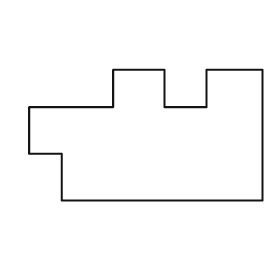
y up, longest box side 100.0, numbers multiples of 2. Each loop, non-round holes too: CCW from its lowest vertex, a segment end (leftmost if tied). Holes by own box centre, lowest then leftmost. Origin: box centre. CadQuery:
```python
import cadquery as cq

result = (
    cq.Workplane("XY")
    .moveTo(-36.0, -28.0)
    .lineTo(50.0, -28.0)
    .lineTo(50.0, 28.0)
    .lineTo(26.0, 28.0)
    .lineTo(26.0, 12.0)
    .lineTo(8.0, 12.0)
    .lineTo(8.0, 28.0)
    .lineTo(-14.0, 28.0)
    .lineTo(-14.0, 12.0)
    .lineTo(-50.0, 12.0)
    .lineTo(-50.0, -8.0)
    .lineTo(-36.0, -8.0)
    .close()
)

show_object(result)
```